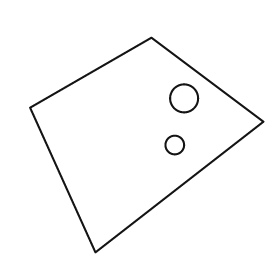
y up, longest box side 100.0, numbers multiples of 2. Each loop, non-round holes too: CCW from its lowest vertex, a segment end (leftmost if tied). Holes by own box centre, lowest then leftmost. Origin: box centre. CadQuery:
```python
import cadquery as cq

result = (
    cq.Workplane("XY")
    .moveTo(-22.0, -46.0)
    .lineTo(50.0, 10.0)
    .lineTo(2.0, 46.0)
    .lineTo(-50.0, 16.0)
    .close()
    .moveTo(12.0, 0.0)
    .circle(4.0)
    .moveTo(16.0, 20.0)
    .circle(6.0)
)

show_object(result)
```